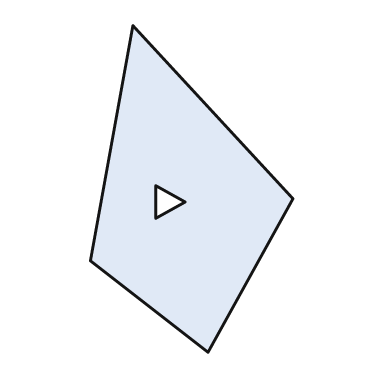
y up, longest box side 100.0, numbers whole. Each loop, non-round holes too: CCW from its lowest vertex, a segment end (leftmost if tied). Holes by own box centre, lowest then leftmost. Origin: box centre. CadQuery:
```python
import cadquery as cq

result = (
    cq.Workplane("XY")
    .moveTo(5.0, -50.0)
    .lineTo(31.0, -3.0)
    .lineTo(-18.0, 50.0)
    .lineTo(-31.0, -22.0)
    .close()
    .moveTo(-11.0, -9.0)
    .lineTo(-2.0, -4.0)
    .lineTo(-11.0, 1.0)
    .close()
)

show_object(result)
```